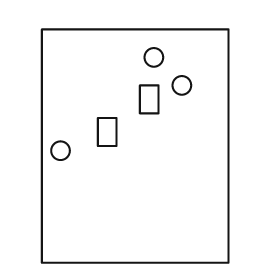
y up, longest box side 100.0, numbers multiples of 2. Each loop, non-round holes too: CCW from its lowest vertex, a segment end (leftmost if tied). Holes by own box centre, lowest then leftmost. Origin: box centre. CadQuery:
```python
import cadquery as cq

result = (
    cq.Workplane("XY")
    .moveTo(-40.0, -50.0)
    .lineTo(40.0, -50.0)
    .lineTo(40.0, 50.0)
    .lineTo(-40.0, 50.0)
    .close()
    .moveTo(-32.0, -2.0)
    .circle(4.0)
    .moveTo(-16.0, 0.0)
    .lineTo(-8.0, 0.0)
    .lineTo(-8.0, 12.0)
    .lineTo(-16.0, 12.0)
    .close()
    .moveTo(2.0, 14.0)
    .lineTo(10.0, 14.0)
    .lineTo(10.0, 26.0)
    .lineTo(2.0, 26.0)
    .close()
    .moveTo(20.0, 26.0)
    .circle(4.0)
    .moveTo(8.0, 38.0)
    .circle(4.0)
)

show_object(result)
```